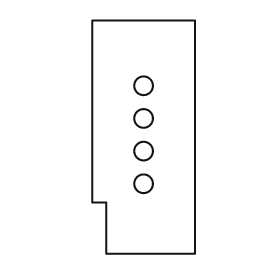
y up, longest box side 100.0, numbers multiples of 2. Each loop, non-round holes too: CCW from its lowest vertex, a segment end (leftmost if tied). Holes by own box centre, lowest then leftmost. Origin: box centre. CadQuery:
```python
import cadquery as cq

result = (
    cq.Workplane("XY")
    .moveTo(-16.0, -50.0)
    .lineTo(22.0, -50.0)
    .lineTo(22.0, 50.0)
    .lineTo(-22.0, 50.0)
    .lineTo(-22.0, -28.0)
    .lineTo(-16.0, -28.0)
    .close()
    .moveTo(0.0, -20.0)
    .circle(4.0)
    .moveTo(0.0, -6.0)
    .circle(4.0)
    .moveTo(0.0, 8.0)
    .circle(4.0)
    .moveTo(0.0, 22.0)
    .circle(4.0)
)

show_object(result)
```